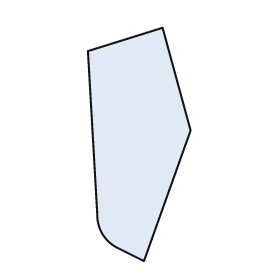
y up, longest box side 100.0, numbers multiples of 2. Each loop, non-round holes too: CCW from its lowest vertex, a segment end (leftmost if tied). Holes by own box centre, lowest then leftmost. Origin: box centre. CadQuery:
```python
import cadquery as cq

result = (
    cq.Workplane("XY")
    .moveTo(2.0, -50.0)
    .lineTo(22.0, 6.0)
    .lineTo(10.0, 50.0)
    .lineTo(-22.0, 40.0)
    .lineTo(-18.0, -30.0)
    .threePointArc((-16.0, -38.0), (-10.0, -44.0))
    .close()
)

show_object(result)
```